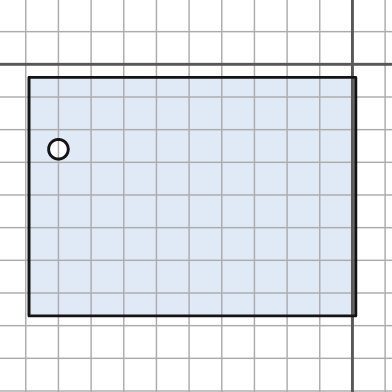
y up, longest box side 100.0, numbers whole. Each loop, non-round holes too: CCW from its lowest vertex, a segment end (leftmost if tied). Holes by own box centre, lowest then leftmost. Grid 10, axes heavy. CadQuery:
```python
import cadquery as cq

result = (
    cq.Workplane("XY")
    .moveTo(-99.0, -77.0)
    .lineTo(1.0, -77.0)
    .lineTo(1.0, -4.0)
    .lineTo(-99.0, -4.0)
    .close()
    .moveTo(-90.0, -26.0)
    .circle(3.0)
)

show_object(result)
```